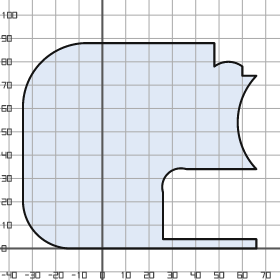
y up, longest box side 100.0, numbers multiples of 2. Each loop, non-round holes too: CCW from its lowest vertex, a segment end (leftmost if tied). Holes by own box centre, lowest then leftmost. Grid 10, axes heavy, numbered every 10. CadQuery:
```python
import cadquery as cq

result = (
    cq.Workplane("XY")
    .moveTo(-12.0, 0.0)
    .lineTo(66.0, 0.0)
    .lineTo(66.0, 4.0)
    .lineTo(26.0, 4.0)
    .lineTo(26.0, 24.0)
    .threePointArc((28.0, 32.0), (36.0, 34.0))
    .lineTo(66.0, 34.0)
    .threePointArc((58.0, 54.0), (66.0, 74.0))
    .lineTo(60.0, 74.0)
    .lineTo(60.0, 78.0)
    .threePointArc((54.0, 80.0), (48.0, 78.0))
    .lineTo(48.0, 88.0)
    .lineTo(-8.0, 88.0)
    .threePointArc((-26.0, 80.0), (-34.0, 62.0))
    .lineTo(-34.0, 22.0)
    .threePointArc((-28.0, 6.0), (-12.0, 0.0))
    .close()
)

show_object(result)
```